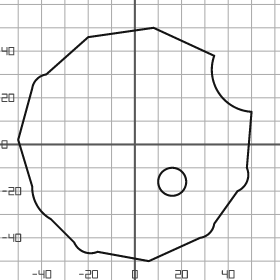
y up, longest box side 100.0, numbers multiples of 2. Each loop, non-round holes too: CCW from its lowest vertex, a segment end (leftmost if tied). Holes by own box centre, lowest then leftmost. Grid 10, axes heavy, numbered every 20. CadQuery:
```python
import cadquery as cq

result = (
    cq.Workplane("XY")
    .moveTo(6.0, -50.0)
    .lineTo(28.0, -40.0)
    .threePointArc((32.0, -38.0), (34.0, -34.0))
    .lineTo(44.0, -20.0)
    .threePointArc((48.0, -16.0), (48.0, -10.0))
    .lineTo(50.0, 14.0)
    .threePointArc((36.0, 22.0), (34.0, 38.0))
    .lineTo(8.0, 50.0)
    .lineTo(-20.0, 46.0)
    .lineTo(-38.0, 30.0)
    .threePointArc((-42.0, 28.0), (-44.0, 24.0))
    .lineTo(-50.0, 2.0)
    .lineTo(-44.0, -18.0)
    .threePointArc((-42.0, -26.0), (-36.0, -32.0))
    .lineTo(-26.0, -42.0)
    .threePointArc((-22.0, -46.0), (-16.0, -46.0))
    .close()
    .moveTo(16.0, -16.0)
    .circle(6.0)
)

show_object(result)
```